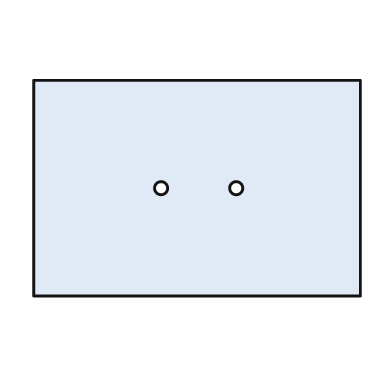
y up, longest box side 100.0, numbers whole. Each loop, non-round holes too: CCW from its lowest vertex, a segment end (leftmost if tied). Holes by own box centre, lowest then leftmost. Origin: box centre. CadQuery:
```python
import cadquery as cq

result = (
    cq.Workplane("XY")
    .moveTo(-50.0, -33.0)
    .lineTo(50.0, -33.0)
    .lineTo(50.0, 33.0)
    .lineTo(-50.0, 33.0)
    .close()
    .moveTo(-11.0, 0.0)
    .circle(2.0)
    .moveTo(12.0, 0.0)
    .circle(2.0)
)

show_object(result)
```